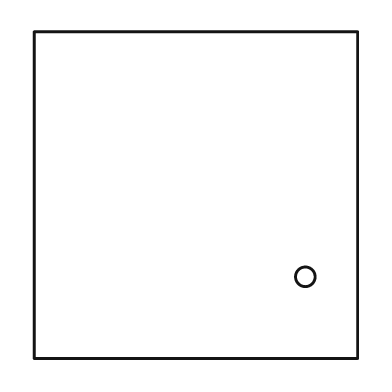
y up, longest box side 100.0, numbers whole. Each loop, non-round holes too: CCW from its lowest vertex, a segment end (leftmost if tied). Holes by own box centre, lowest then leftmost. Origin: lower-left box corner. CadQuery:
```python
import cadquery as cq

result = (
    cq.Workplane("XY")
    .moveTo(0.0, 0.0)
    .lineTo(99.0, 0.0)
    .lineTo(99.0, 100.0)
    .lineTo(0.0, 100.0)
    .close()
    .moveTo(83.0, 25.0)
    .circle(3.0)
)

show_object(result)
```